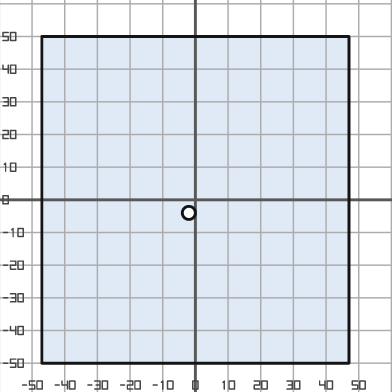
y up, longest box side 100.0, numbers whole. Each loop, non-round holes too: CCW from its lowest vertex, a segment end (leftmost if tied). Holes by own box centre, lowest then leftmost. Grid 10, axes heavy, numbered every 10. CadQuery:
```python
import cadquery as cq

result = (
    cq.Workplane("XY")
    .moveTo(-47.0, -50.0)
    .lineTo(47.0, -50.0)
    .lineTo(47.0, 50.0)
    .lineTo(-47.0, 50.0)
    .close()
    .moveTo(-2.0, -4.0)
    .circle(2.0)
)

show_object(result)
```